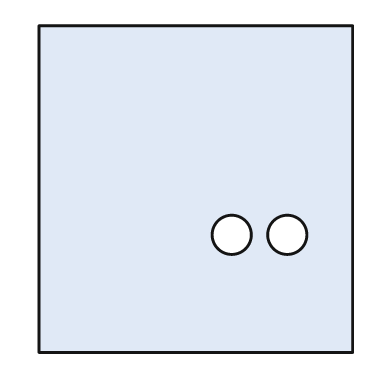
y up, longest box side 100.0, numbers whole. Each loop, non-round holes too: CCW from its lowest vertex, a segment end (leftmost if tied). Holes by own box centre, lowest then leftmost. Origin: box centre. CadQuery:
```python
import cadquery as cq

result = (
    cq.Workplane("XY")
    .moveTo(-48.0, -50.0)
    .lineTo(48.0, -50.0)
    .lineTo(48.0, 50.0)
    .lineTo(-48.0, 50.0)
    .close()
    .moveTo(11.0, -14.0)
    .circle(6.0)
    .moveTo(28.0, -14.0)
    .circle(6.0)
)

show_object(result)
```